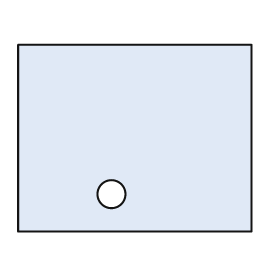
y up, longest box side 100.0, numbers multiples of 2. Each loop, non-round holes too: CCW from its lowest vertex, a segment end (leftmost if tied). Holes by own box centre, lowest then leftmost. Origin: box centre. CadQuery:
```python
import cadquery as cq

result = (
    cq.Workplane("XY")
    .moveTo(-50.0, -40.0)
    .lineTo(50.0, -40.0)
    .lineTo(50.0, 40.0)
    .lineTo(-50.0, 40.0)
    .close()
    .moveTo(-10.0, -24.0)
    .circle(6.0)
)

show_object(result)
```